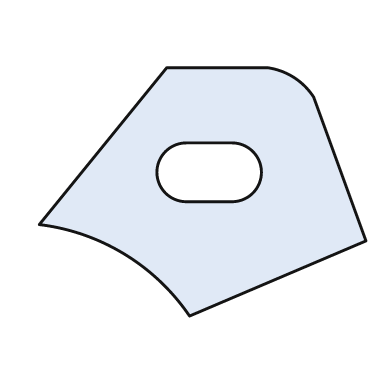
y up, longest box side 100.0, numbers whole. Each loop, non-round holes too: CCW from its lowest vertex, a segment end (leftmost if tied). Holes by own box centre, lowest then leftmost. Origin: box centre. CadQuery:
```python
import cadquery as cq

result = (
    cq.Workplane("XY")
    .moveTo(-4.0, -38.0)
    .lineTo(50.0, -15.0)
    .lineTo(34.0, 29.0)
    .threePointArc((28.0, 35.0), (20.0, 38.0))
    .lineTo(-11.0, 38.0)
    .lineTo(-50.0, -10.0)
    .threePointArc((-24.0, -19.0), (-4.0, -38.0))
    .close()
    .moveTo(-5.0, -3.0)
    .lineTo(9.0, -3.0)
    .threePointArc((18.0, 6.0), (9.0, 15.0))
    .lineTo(-5.0, 15.0)
    .threePointArc((-14.0, 6.0), (-5.0, -3.0))
    .close()
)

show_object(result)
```